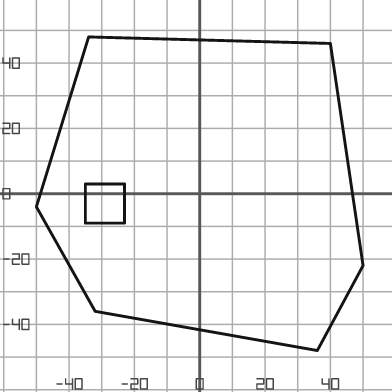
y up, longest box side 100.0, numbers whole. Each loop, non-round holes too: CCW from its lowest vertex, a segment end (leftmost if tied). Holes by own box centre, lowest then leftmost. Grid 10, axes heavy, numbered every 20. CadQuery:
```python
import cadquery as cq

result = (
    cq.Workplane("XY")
    .moveTo(36.0, -48.0)
    .lineTo(50.0, -22.0)
    .lineTo(40.0, 46.0)
    .lineTo(-34.0, 48.0)
    .lineTo(-50.0, -4.0)
    .lineTo(-32.0, -36.0)
    .close()
    .moveTo(-35.0, -9.0)
    .lineTo(-23.0, -9.0)
    .lineTo(-23.0, 3.0)
    .lineTo(-35.0, 3.0)
    .close()
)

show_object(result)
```